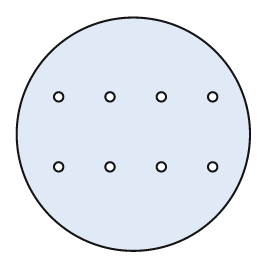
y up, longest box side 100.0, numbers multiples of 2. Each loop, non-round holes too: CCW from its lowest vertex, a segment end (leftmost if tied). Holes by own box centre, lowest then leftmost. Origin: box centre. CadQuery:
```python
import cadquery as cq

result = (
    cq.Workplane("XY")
    .moveTo(0.0, 0.0)
    .circle(50.0)
    .moveTo(-32.0, -14.0)
    .circle(2.0)
    .moveTo(-10.0, -14.0)
    .circle(2.0)
    .moveTo(12.0, -14.0)
    .circle(2.0)
    .moveTo(34.0, -14.0)
    .circle(2.0)
    .moveTo(-32.0, 16.0)
    .circle(2.0)
    .moveTo(-10.0, 16.0)
    .circle(2.0)
    .moveTo(12.0, 16.0)
    .circle(2.0)
    .moveTo(34.0, 16.0)
    .circle(2.0)
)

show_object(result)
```